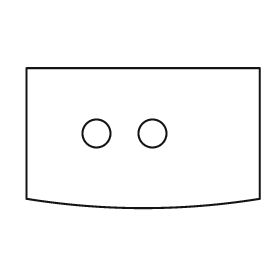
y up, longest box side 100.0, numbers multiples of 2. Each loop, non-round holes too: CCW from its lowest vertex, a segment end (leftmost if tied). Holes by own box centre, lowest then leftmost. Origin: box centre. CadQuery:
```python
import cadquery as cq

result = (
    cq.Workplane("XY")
    .moveTo(-50.0, -26.0)
    .threePointArc((0.0, -30.0), (50.0, -26.0))
    .lineTo(50.0, 30.0)
    .lineTo(-50.0, 30.0)
    .close()
    .moveTo(-20.0, 2.0)
    .circle(6.0)
    .moveTo(4.0, 2.0)
    .circle(6.0)
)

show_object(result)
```